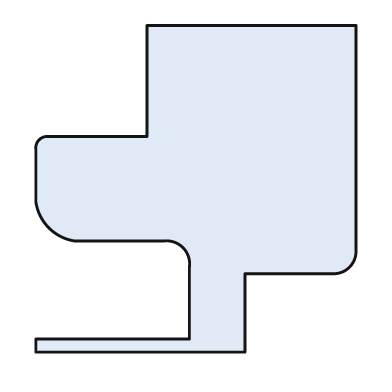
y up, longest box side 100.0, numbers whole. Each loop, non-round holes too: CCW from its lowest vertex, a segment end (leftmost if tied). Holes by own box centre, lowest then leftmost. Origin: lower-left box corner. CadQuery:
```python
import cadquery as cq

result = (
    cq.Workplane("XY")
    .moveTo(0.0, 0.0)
    .lineTo(64.0, 0.0)
    .lineTo(64.0, 24.0)
    .lineTo(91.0, 24.0)
    .threePointArc((96.0, 26.0), (98.0, 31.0))
    .lineTo(98.0, 100.0)
    .lineTo(34.0, 100.0)
    .lineTo(34.0, 66.0)
    .lineTo(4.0, 66.0)
    .threePointArc((1.0, 65.0), (0.0, 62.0))
    .lineTo(0.0, 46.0)
    .threePointArc((4.0, 38.0), (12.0, 34.0))
    .lineTo(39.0, 34.0)
    .threePointArc((45.0, 32.0), (47.0, 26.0))
    .lineTo(47.0, 4.0)
    .lineTo(0.0, 4.0)
    .close()
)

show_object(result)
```